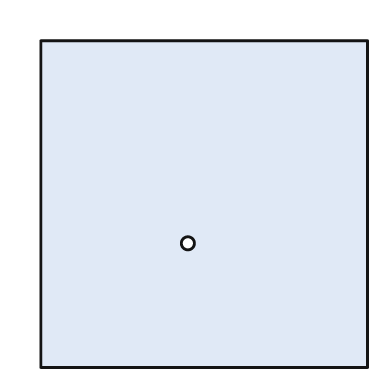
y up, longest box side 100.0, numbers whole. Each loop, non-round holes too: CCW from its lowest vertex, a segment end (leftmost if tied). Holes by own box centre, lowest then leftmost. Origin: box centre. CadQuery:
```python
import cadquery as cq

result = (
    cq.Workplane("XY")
    .moveTo(-50.0, -50.0)
    .lineTo(50.0, -50.0)
    .lineTo(50.0, 50.0)
    .lineTo(-50.0, 50.0)
    .close()
    .moveTo(-5.0, -12.0)
    .circle(2.0)
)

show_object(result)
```